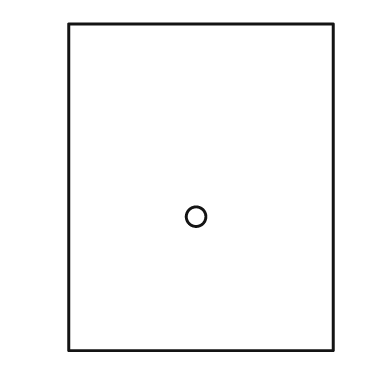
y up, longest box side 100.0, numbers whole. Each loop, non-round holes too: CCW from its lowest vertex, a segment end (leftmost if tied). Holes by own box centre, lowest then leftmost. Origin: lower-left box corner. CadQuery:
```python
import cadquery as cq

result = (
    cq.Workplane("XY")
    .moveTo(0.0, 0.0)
    .lineTo(81.0, 0.0)
    .lineTo(81.0, 100.0)
    .lineTo(0.0, 100.0)
    .close()
    .moveTo(39.0, 41.0)
    .circle(3.0)
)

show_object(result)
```